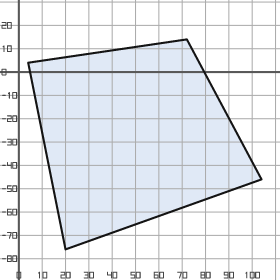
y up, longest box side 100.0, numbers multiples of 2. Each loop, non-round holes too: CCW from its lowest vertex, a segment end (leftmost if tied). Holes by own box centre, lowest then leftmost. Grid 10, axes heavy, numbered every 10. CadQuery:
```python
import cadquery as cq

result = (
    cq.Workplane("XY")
    .moveTo(20.0, -76.0)
    .lineTo(104.0, -46.0)
    .lineTo(72.0, 14.0)
    .lineTo(4.0, 4.0)
    .close()
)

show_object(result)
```